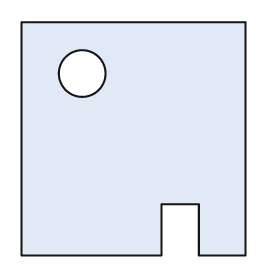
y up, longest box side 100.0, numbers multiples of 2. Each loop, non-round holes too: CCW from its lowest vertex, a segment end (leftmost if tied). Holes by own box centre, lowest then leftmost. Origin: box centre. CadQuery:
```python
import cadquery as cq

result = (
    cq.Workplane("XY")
    .moveTo(-48.0, -50.0)
    .lineTo(12.0, -50.0)
    .lineTo(12.0, -28.0)
    .lineTo(28.0, -28.0)
    .lineTo(28.0, -50.0)
    .lineTo(48.0, -50.0)
    .lineTo(48.0, 50.0)
    .lineTo(-48.0, 50.0)
    .close()
    .moveTo(-22.0, 28.0)
    .circle(10.0)
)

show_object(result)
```